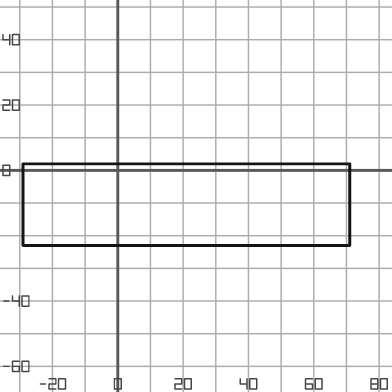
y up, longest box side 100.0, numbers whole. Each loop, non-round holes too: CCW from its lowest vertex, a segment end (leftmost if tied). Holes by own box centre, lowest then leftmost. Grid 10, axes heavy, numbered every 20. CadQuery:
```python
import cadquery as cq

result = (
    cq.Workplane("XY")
    .moveTo(-29.0, -23.0)
    .lineTo(71.0, -23.0)
    .lineTo(71.0, 2.0)
    .lineTo(-29.0, 2.0)
    .close()
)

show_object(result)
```